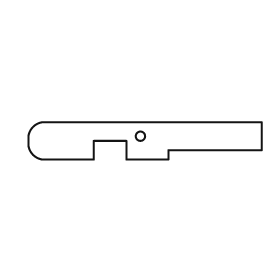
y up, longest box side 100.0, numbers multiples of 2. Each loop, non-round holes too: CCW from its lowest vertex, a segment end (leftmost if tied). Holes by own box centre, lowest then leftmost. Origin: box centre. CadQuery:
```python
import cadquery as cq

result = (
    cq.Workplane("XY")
    .moveTo(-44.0, -8.0)
    .lineTo(-22.0, -8.0)
    .lineTo(-22.0, 0.0)
    .lineTo(-8.0, 0.0)
    .lineTo(-8.0, -8.0)
    .lineTo(10.0, -8.0)
    .lineTo(10.0, -4.0)
    .lineTo(50.0, -4.0)
    .lineTo(50.0, 8.0)
    .lineTo(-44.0, 8.0)
    .threePointArc((-48.0, 6.0), (-50.0, 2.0))
    .lineTo(-50.0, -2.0)
    .threePointArc((-48.0, -6.0), (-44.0, -8.0))
    .close()
    .moveTo(-2.0, 2.0)
    .circle(2.0)
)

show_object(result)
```